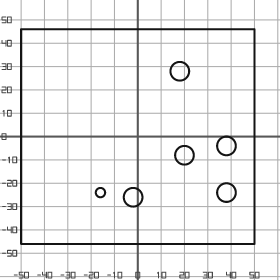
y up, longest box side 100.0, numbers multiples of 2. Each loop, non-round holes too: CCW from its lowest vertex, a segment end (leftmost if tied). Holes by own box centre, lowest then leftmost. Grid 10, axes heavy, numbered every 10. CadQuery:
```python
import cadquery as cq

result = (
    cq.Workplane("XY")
    .moveTo(-50.0, -46.0)
    .lineTo(50.0, -46.0)
    .lineTo(50.0, 46.0)
    .lineTo(-50.0, 46.0)
    .close()
    .moveTo(-2.0, -26.0)
    .circle(4.0)
    .moveTo(-16.0, -24.0)
    .circle(2.0)
    .moveTo(38.0, -24.0)
    .circle(4.0)
    .moveTo(20.0, -8.0)
    .circle(4.0)
    .moveTo(38.0, -4.0)
    .circle(4.0)
    .moveTo(18.0, 28.0)
    .circle(4.0)
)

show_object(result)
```